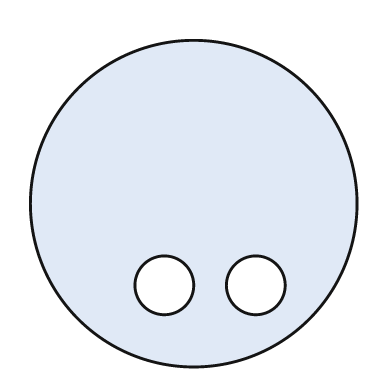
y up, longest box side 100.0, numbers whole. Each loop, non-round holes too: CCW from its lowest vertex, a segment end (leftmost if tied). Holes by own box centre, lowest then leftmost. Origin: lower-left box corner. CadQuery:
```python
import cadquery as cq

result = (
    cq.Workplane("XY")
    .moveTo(50.0, 50.0)
    .circle(50.0)
    .moveTo(41.0, 25.0)
    .circle(9.0)
    .moveTo(69.0, 25.0)
    .circle(9.0)
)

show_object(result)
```